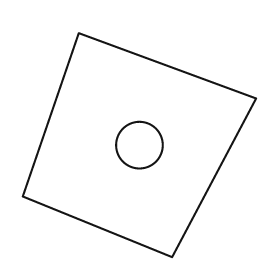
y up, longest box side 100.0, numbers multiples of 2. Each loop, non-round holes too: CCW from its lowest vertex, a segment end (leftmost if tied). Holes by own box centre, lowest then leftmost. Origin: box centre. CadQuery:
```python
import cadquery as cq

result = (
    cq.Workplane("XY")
    .moveTo(14.0, -48.0)
    .lineTo(50.0, 20.0)
    .lineTo(-26.0, 48.0)
    .lineTo(-50.0, -22.0)
    .close()
    .moveTo(0.0, 0.0)
    .circle(10.0)
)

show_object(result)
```